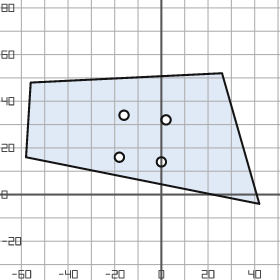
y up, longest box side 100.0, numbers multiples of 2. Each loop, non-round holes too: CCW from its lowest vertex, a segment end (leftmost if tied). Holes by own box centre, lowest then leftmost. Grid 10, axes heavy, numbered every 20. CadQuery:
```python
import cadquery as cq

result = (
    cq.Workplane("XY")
    .moveTo(42.0, -4.0)
    .lineTo(26.0, 52.0)
    .lineTo(-56.0, 48.0)
    .lineTo(-58.0, 16.0)
    .close()
    .moveTo(0.0, 14.0)
    .circle(2.0)
    .moveTo(-18.0, 16.0)
    .circle(2.0)
    .moveTo(2.0, 32.0)
    .circle(2.0)
    .moveTo(-16.0, 34.0)
    .circle(2.0)
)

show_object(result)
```